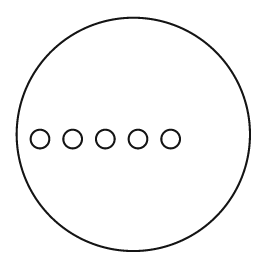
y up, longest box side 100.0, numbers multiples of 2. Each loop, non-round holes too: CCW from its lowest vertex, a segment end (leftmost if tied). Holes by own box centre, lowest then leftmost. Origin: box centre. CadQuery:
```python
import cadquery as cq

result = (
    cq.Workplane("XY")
    .moveTo(0.0, 0.0)
    .circle(50.0)
    .moveTo(-40.0, -2.0)
    .circle(4.0)
    .moveTo(-26.0, -2.0)
    .circle(4.0)
    .moveTo(-12.0, -2.0)
    .circle(4.0)
    .moveTo(2.0, -2.0)
    .circle(4.0)
    .moveTo(16.0, -2.0)
    .circle(4.0)
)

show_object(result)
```